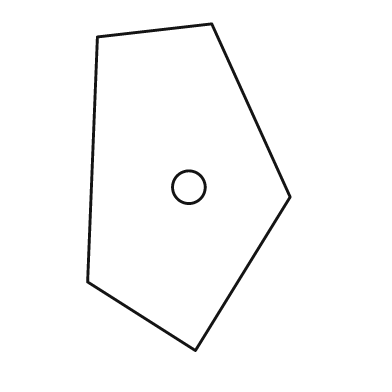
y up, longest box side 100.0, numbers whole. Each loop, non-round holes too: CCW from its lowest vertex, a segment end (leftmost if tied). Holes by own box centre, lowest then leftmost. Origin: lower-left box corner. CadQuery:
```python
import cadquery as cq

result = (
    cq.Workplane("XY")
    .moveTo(33.0, 0.0)
    .lineTo(62.0, 47.0)
    .lineTo(38.0, 100.0)
    .lineTo(3.0, 96.0)
    .lineTo(0.0, 21.0)
    .close()
    .moveTo(31.0, 50.0)
    .circle(5.0)
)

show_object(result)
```